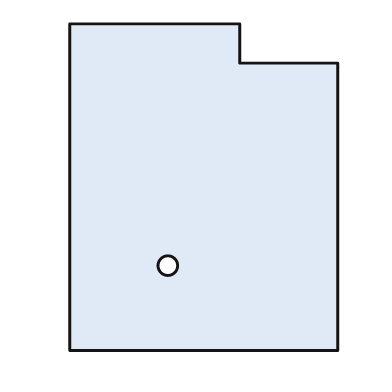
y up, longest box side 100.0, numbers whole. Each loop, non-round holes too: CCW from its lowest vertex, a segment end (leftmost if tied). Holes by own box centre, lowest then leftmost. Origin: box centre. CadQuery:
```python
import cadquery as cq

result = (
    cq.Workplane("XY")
    .moveTo(-41.0, -50.0)
    .lineTo(41.0, -50.0)
    .lineTo(41.0, 38.0)
    .lineTo(11.0, 38.0)
    .lineTo(11.0, 50.0)
    .lineTo(-41.0, 50.0)
    .close()
    .moveTo(-11.0, -24.0)
    .circle(3.0)
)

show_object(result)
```